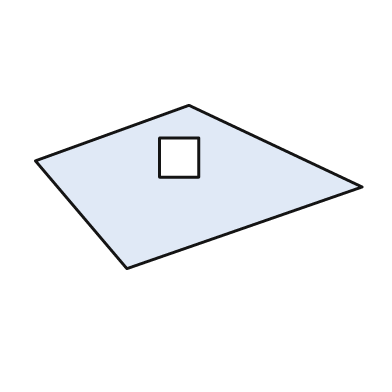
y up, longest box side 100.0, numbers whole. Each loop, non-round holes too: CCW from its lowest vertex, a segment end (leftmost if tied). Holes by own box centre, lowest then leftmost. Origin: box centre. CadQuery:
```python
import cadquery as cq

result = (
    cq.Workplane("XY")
    .moveTo(-22.0, -25.0)
    .lineTo(50.0, 0.0)
    .lineTo(-3.0, 25.0)
    .lineTo(-50.0, 8.0)
    .close()
    .moveTo(-12.0, 3.0)
    .lineTo(0.0, 3.0)
    .lineTo(0.0, 15.0)
    .lineTo(-12.0, 15.0)
    .close()
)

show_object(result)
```